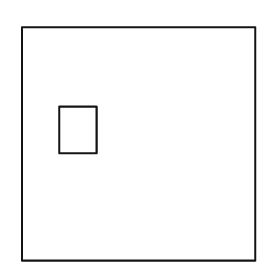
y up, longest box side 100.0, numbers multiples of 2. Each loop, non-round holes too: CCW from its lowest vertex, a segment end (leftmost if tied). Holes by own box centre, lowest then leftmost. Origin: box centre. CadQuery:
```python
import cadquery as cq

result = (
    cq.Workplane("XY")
    .moveTo(-50.0, -50.0)
    .lineTo(50.0, -50.0)
    .lineTo(50.0, 50.0)
    .lineTo(-50.0, 50.0)
    .close()
    .moveTo(-34.0, -4.0)
    .lineTo(-18.0, -4.0)
    .lineTo(-18.0, 16.0)
    .lineTo(-34.0, 16.0)
    .close()
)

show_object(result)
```